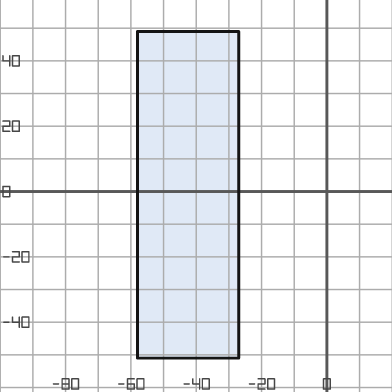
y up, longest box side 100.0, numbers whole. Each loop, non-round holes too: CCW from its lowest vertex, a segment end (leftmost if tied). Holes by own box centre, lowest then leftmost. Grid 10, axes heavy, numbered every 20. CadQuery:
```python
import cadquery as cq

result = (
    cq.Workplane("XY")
    .moveTo(-58.0, -51.0)
    .lineTo(-27.0, -51.0)
    .lineTo(-27.0, 49.0)
    .lineTo(-58.0, 49.0)
    .close()
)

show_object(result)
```